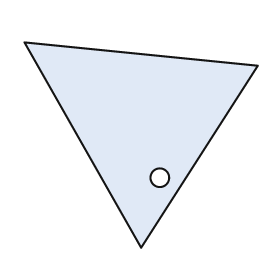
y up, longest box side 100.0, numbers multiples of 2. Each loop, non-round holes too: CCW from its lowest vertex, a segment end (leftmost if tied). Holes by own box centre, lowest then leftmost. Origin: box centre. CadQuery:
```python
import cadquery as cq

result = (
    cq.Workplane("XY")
    .moveTo(0.0, -44.0)
    .lineTo(50.0, 34.0)
    .lineTo(-50.0, 44.0)
    .close()
    .moveTo(8.0, -14.0)
    .circle(4.0)
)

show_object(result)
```